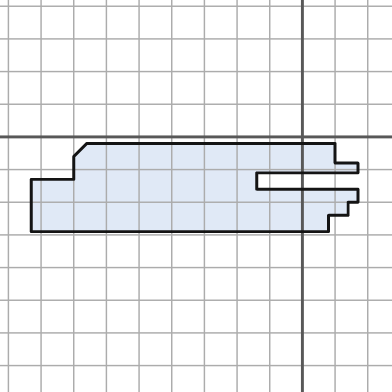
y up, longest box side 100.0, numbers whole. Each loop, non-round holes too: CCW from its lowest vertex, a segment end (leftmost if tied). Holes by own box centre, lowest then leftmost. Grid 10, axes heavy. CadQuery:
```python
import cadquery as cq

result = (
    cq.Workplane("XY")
    .moveTo(-83.0, -29.0)
    .lineTo(8.0, -29.0)
    .lineTo(8.0, -24.0)
    .lineTo(14.0, -24.0)
    .lineTo(14.0, -20.0)
    .lineTo(17.0, -20.0)
    .lineTo(17.0, -16.0)
    .lineTo(-14.0, -16.0)
    .lineTo(-14.0, -11.0)
    .lineTo(17.0, -11.0)
    .lineTo(17.0, -8.0)
    .lineTo(10.0, -8.0)
    .lineTo(10.0, -2.0)
    .lineTo(-66.0, -2.0)
    .lineTo(-70.0, -6.0)
    .lineTo(-70.0, -13.0)
    .lineTo(-83.0, -13.0)
    .close()
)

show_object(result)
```